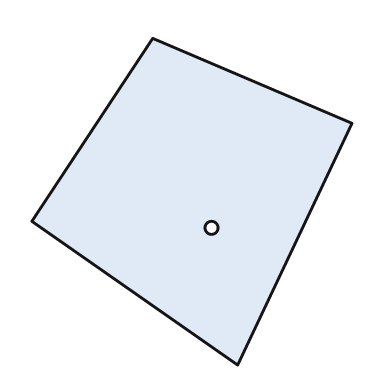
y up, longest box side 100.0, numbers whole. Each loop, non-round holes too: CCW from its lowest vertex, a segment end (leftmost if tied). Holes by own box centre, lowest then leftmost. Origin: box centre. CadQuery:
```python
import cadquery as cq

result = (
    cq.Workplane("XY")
    .moveTo(14.0, -50.0)
    .lineTo(49.0, 24.0)
    .lineTo(-12.0, 50.0)
    .lineTo(-49.0, -6.0)
    .close()
    .moveTo(6.0, -8.0)
    .circle(2.0)
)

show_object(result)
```